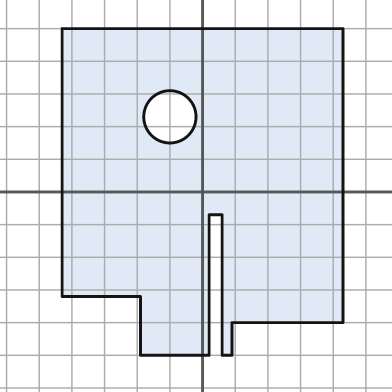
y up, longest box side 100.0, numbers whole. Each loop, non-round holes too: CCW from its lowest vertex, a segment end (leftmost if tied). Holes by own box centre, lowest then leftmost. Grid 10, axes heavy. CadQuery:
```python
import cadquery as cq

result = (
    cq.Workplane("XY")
    .moveTo(-19.0, -50.0)
    .lineTo(2.0, -50.0)
    .lineTo(2.0, -7.0)
    .lineTo(6.0, -7.0)
    .lineTo(6.0, -50.0)
    .lineTo(9.0, -50.0)
    .lineTo(9.0, -40.0)
    .lineTo(43.0, -40.0)
    .lineTo(43.0, 50.0)
    .lineTo(-43.0, 50.0)
    .lineTo(-43.0, -32.0)
    .lineTo(-19.0, -32.0)
    .close()
    .moveTo(-10.0, 23.0)
    .circle(8.0)
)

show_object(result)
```